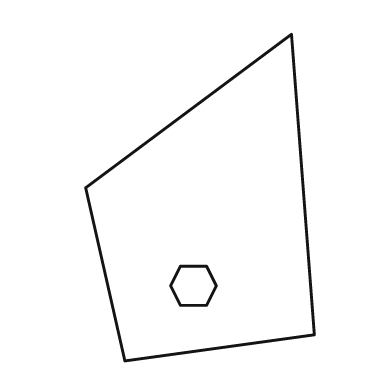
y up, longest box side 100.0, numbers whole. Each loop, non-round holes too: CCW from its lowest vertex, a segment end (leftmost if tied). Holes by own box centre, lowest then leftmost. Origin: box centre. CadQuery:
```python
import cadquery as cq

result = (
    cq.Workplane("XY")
    .moveTo(-23.0, -50.0)
    .lineTo(35.0, -42.0)
    .lineTo(28.0, 50.0)
    .lineTo(-35.0, 3.0)
    .close()
    .moveTo(-6.0, -33.0)
    .lineTo(2.0, -33.0)
    .lineTo(5.0, -27.0)
    .lineTo(2.0, -21.0)
    .lineTo(-6.0, -21.0)
    .lineTo(-9.0, -27.0)
    .close()
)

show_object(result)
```